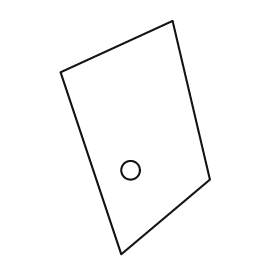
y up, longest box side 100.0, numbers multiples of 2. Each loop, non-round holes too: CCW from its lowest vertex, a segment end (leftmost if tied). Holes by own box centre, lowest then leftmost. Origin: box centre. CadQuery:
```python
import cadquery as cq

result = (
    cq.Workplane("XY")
    .moveTo(-6.0, -50.0)
    .lineTo(32.0, -18.0)
    .lineTo(16.0, 50.0)
    .lineTo(-32.0, 28.0)
    .close()
    .moveTo(-2.0, -14.0)
    .circle(4.0)
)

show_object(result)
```